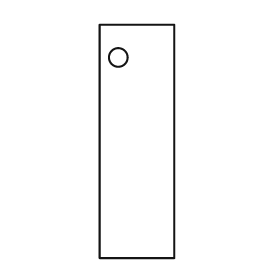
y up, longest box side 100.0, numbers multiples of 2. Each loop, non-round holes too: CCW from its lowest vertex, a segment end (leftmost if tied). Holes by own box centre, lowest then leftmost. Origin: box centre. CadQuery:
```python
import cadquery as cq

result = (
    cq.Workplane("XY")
    .moveTo(-16.0, -50.0)
    .lineTo(16.0, -50.0)
    .lineTo(16.0, 50.0)
    .lineTo(-16.0, 50.0)
    .close()
    .moveTo(-8.0, 36.0)
    .circle(4.0)
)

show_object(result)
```